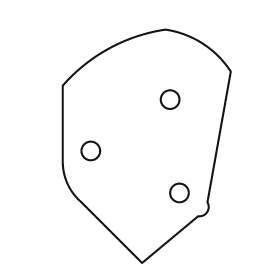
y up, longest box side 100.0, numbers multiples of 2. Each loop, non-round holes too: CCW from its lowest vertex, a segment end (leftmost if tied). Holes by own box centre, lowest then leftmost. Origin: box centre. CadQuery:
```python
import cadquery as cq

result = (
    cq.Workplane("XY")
    .moveTo(-2.0, -50.0)
    .lineTo(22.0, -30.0)
    .threePointArc((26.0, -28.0), (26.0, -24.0))
    .lineTo(36.0, 32.0)
    .threePointArc((24.0, 44.0), (8.0, 50.0))
    .threePointArc((-16.0, 42.0), (-36.0, 26.0))
    .lineTo(-36.0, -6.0)
    .threePointArc((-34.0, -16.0), (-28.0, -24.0))
    .close()
    .moveTo(14.0, -20.0)
    .circle(4.0)
    .moveTo(-24.0, -2.0)
    .circle(4.0)
    .moveTo(10.0, 20.0)
    .circle(4.0)
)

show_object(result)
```